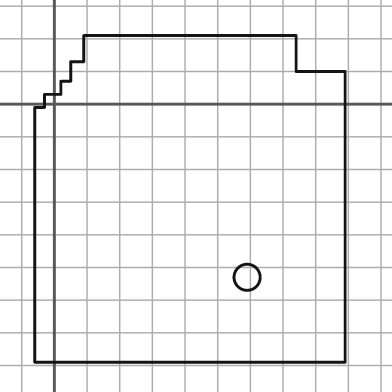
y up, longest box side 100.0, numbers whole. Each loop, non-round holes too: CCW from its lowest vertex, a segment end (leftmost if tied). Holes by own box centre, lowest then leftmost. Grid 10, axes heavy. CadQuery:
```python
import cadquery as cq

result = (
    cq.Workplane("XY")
    .moveTo(-6.0, -79.0)
    .lineTo(89.0, -79.0)
    .lineTo(89.0, 10.0)
    .lineTo(74.0, 10.0)
    .lineTo(74.0, 21.0)
    .lineTo(9.0, 21.0)
    .lineTo(9.0, 13.0)
    .lineTo(5.0, 13.0)
    .lineTo(5.0, 7.0)
    .lineTo(2.0, 7.0)
    .lineTo(2.0, 3.0)
    .lineTo(-3.0, 3.0)
    .lineTo(-3.0, -1.0)
    .lineTo(-6.0, -1.0)
    .close()
    .moveTo(59.0, -53.0)
    .circle(4.0)
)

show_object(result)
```